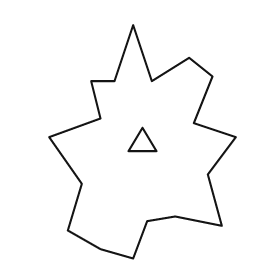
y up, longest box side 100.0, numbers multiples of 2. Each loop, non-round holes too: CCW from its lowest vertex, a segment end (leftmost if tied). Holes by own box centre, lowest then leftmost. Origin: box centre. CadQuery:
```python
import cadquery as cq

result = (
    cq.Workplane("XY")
    .moveTo(-4.0, -50.0)
    .lineTo(2.0, -34.0)
    .lineTo(14.0, -32.0)
    .lineTo(34.0, -36.0)
    .lineTo(28.0, -14.0)
    .lineTo(40.0, 2.0)
    .lineTo(22.0, 8.0)
    .lineTo(30.0, 28.0)
    .lineTo(20.0, 36.0)
    .lineTo(4.0, 26.0)
    .lineTo(-4.0, 50.0)
    .lineTo(-12.0, 26.0)
    .lineTo(-22.0, 26.0)
    .lineTo(-18.0, 10.0)
    .lineTo(-40.0, 2.0)
    .lineTo(-26.0, -18.0)
    .lineTo(-32.0, -38.0)
    .lineTo(-18.0, -46.0)
    .close()
    .moveTo(-6.0, -4.0)
    .lineTo(6.0, -4.0)
    .lineTo(0.0, 6.0)
    .close()
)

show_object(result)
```